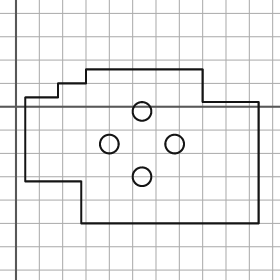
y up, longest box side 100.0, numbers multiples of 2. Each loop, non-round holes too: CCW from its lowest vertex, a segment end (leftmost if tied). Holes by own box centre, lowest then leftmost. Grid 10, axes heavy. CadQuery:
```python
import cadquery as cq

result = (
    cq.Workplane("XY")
    .moveTo(28.0, -50.0)
    .lineTo(104.0, -50.0)
    .lineTo(104.0, 2.0)
    .lineTo(80.0, 2.0)
    .lineTo(80.0, 16.0)
    .lineTo(30.0, 16.0)
    .lineTo(30.0, 10.0)
    .lineTo(18.0, 10.0)
    .lineTo(18.0, 4.0)
    .lineTo(4.0, 4.0)
    .lineTo(4.0, -32.0)
    .lineTo(28.0, -32.0)
    .close()
    .moveTo(54.0, -30.0)
    .circle(4.0)
    .moveTo(40.0, -16.0)
    .circle(4.0)
    .moveTo(68.0, -16.0)
    .circle(4.0)
    .moveTo(54.0, -2.0)
    .circle(4.0)
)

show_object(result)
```